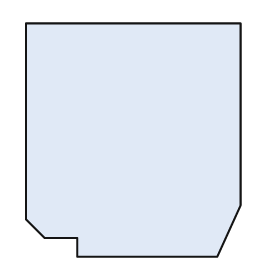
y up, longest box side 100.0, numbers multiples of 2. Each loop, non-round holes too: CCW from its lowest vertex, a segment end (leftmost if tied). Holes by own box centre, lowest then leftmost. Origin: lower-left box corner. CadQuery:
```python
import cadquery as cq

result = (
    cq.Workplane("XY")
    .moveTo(22.0, 0.0)
    .lineTo(82.0, 0.0)
    .lineTo(92.0, 22.0)
    .lineTo(92.0, 100.0)
    .lineTo(0.0, 100.0)
    .lineTo(0.0, 16.0)
    .lineTo(8.0, 8.0)
    .lineTo(22.0, 8.0)
    .close()
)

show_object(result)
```